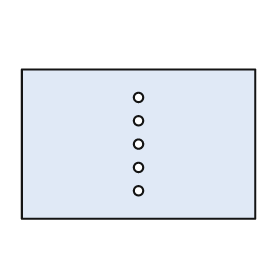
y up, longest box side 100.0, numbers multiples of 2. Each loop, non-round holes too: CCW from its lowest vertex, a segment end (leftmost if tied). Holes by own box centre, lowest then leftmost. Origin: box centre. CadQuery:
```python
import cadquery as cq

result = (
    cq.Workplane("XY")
    .moveTo(-50.0, -32.0)
    .lineTo(50.0, -32.0)
    .lineTo(50.0, 32.0)
    .lineTo(-50.0, 32.0)
    .close()
    .moveTo(0.0, -20.0)
    .circle(2.0)
    .moveTo(0.0, -10.0)
    .circle(2.0)
    .moveTo(0.0, 0.0)
    .circle(2.0)
    .moveTo(0.0, 10.0)
    .circle(2.0)
    .moveTo(0.0, 20.0)
    .circle(2.0)
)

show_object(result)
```